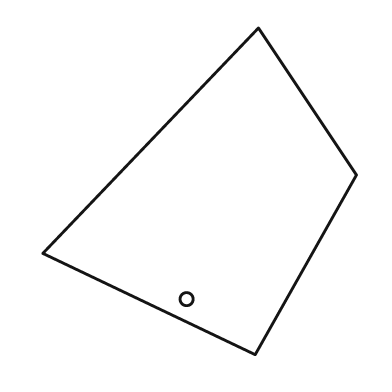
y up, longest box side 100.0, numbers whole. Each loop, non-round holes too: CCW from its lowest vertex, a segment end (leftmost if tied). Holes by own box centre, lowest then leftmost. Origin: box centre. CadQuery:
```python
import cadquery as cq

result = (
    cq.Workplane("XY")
    .moveTo(17.0, -50.0)
    .lineTo(48.0, 5.0)
    .lineTo(18.0, 50.0)
    .lineTo(-48.0, -19.0)
    .close()
    .moveTo(-4.0, -33.0)
    .circle(2.0)
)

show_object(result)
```